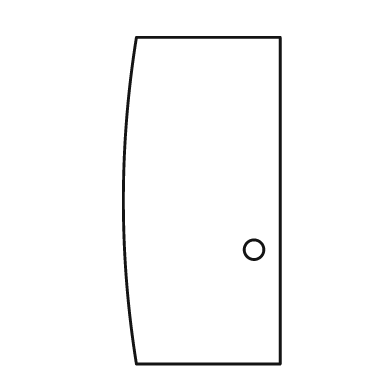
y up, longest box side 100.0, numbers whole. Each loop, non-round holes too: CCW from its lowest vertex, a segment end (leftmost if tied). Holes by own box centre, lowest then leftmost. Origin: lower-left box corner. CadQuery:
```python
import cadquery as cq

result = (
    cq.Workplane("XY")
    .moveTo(4.0, 0.0)
    .lineTo(48.0, 0.0)
    .lineTo(48.0, 100.0)
    .lineTo(4.0, 100.0)
    .threePointArc((0.0, 50.0), (4.0, 0.0))
    .close()
    .moveTo(40.0, 35.0)
    .circle(3.0)
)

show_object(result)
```